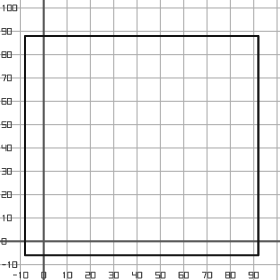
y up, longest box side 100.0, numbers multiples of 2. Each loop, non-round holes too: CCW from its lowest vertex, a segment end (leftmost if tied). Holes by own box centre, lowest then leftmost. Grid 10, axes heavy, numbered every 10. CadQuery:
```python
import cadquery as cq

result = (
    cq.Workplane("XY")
    .moveTo(-8.0, -6.0)
    .lineTo(92.0, -6.0)
    .lineTo(92.0, 88.0)
    .lineTo(-8.0, 88.0)
    .close()
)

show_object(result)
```